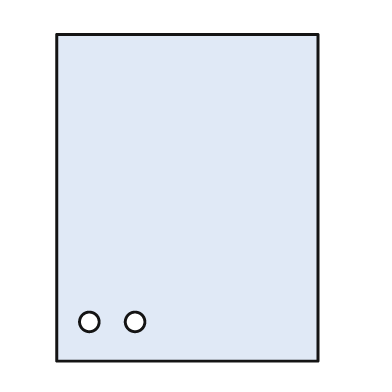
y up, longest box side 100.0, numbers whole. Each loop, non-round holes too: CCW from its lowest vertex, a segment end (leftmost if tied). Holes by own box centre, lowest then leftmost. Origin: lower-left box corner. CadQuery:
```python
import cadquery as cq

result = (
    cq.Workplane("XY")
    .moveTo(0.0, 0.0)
    .lineTo(80.0, 0.0)
    .lineTo(80.0, 100.0)
    .lineTo(0.0, 100.0)
    .close()
    .moveTo(10.0, 12.0)
    .circle(3.0)
    .moveTo(24.0, 12.0)
    .circle(3.0)
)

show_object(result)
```